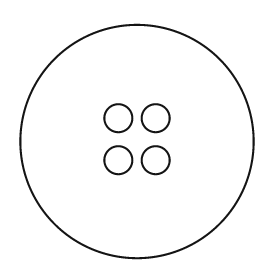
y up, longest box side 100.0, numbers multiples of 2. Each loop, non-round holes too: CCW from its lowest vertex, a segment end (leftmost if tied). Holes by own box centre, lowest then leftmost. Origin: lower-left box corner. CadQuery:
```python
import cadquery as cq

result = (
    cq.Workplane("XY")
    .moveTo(50.0, 50.0)
    .circle(50.0)
    .moveTo(42.0, 42.0)
    .circle(6.0)
    .moveTo(58.0, 42.0)
    .circle(6.0)
    .moveTo(42.0, 60.0)
    .circle(6.0)
    .moveTo(58.0, 60.0)
    .circle(6.0)
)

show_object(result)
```